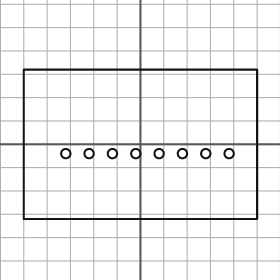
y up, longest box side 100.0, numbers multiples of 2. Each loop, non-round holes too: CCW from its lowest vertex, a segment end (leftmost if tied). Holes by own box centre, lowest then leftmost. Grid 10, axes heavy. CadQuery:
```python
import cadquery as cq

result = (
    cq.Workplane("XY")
    .moveTo(-50.0, -32.0)
    .lineTo(50.0, -32.0)
    .lineTo(50.0, 32.0)
    .lineTo(-50.0, 32.0)
    .close()
    .moveTo(-32.0, -4.0)
    .circle(2.0)
    .moveTo(-22.0, -4.0)
    .circle(2.0)
    .moveTo(-12.0, -4.0)
    .circle(2.0)
    .moveTo(-2.0, -4.0)
    .circle(2.0)
    .moveTo(8.0, -4.0)
    .circle(2.0)
    .moveTo(18.0, -4.0)
    .circle(2.0)
    .moveTo(28.0, -4.0)
    .circle(2.0)
    .moveTo(38.0, -4.0)
    .circle(2.0)
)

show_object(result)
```